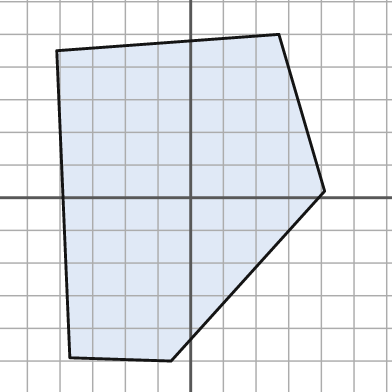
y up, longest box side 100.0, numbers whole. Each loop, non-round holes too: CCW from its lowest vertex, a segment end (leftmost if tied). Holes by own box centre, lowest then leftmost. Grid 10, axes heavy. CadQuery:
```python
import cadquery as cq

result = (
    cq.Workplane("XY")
    .moveTo(-6.0, -50.0)
    .lineTo(41.0, 2.0)
    .lineTo(27.0, 50.0)
    .lineTo(-41.0, 45.0)
    .lineTo(-37.0, -49.0)
    .close()
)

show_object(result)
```